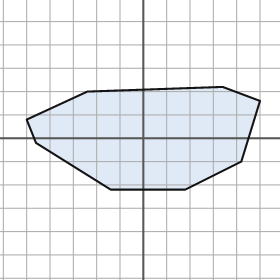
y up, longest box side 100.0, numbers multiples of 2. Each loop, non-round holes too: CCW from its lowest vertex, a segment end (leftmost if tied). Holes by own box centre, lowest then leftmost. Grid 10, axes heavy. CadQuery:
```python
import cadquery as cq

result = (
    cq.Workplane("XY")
    .moveTo(-14.0, -22.0)
    .lineTo(18.0, -22.0)
    .lineTo(42.0, -10.0)
    .lineTo(50.0, 16.0)
    .lineTo(34.0, 22.0)
    .lineTo(-24.0, 20.0)
    .lineTo(-50.0, 8.0)
    .lineTo(-46.0, -2.0)
    .close()
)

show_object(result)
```